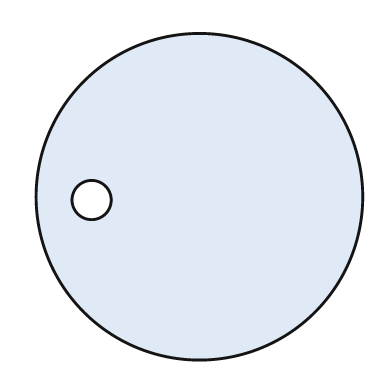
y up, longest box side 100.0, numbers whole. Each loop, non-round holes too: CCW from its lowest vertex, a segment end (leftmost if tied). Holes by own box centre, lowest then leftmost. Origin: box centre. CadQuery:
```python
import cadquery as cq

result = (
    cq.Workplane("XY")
    .moveTo(0.0, 0.0)
    .circle(50.0)
    .moveTo(-33.0, -1.0)
    .circle(6.0)
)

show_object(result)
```